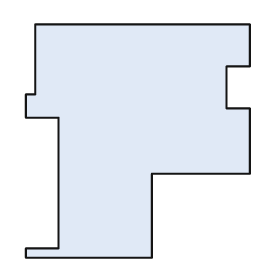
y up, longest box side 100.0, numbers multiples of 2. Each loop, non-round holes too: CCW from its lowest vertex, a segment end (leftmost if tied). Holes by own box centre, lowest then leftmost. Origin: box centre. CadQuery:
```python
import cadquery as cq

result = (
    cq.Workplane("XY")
    .moveTo(-48.0, -50.0)
    .lineTo(6.0, -50.0)
    .lineTo(6.0, -14.0)
    .lineTo(48.0, -14.0)
    .lineTo(48.0, 14.0)
    .lineTo(38.0, 14.0)
    .lineTo(38.0, 32.0)
    .lineTo(48.0, 32.0)
    .lineTo(48.0, 50.0)
    .lineTo(-44.0, 50.0)
    .lineTo(-44.0, 20.0)
    .lineTo(-48.0, 20.0)
    .lineTo(-48.0, 10.0)
    .lineTo(-34.0, 10.0)
    .lineTo(-34.0, -46.0)
    .lineTo(-48.0, -46.0)
    .close()
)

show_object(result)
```